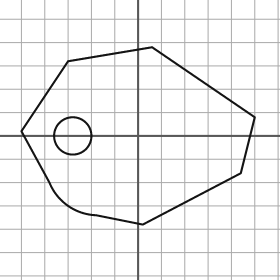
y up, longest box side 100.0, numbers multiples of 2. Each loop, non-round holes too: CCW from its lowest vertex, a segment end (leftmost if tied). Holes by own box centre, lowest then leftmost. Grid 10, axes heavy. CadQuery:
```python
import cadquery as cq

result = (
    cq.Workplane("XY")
    .moveTo(2.0, -38.0)
    .lineTo(44.0, -16.0)
    .lineTo(50.0, 8.0)
    .lineTo(6.0, 38.0)
    .lineTo(-30.0, 32.0)
    .lineTo(-50.0, 2.0)
    .lineTo(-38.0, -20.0)
    .threePointArc((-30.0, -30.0), (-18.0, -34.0))
    .close()
    .moveTo(-28.0, 0.0)
    .circle(8.0)
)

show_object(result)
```